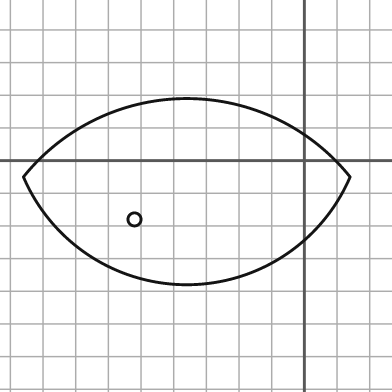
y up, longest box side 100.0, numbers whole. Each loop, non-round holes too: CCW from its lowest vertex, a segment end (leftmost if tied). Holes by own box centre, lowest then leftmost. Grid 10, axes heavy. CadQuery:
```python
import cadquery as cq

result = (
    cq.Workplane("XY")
    .moveTo(-86.0, -5.0)
    .threePointArc((-36.0, -38.0), (14.0, -5.0))
    .threePointArc((-36.0, 19.0), (-86.0, -5.0))
    .close()
    .moveTo(-52.0, -18.0)
    .circle(2.0)
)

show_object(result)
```